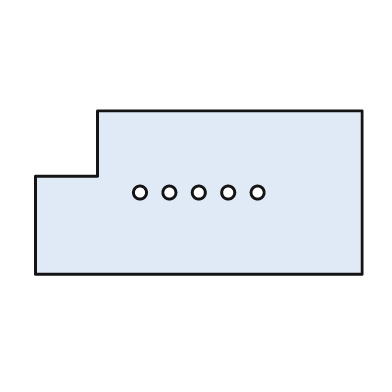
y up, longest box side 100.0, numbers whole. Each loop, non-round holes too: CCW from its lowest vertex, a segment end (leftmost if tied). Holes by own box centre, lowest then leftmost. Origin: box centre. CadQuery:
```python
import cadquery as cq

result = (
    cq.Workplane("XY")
    .moveTo(-50.0, -25.0)
    .lineTo(50.0, -25.0)
    .lineTo(50.0, 25.0)
    .lineTo(-31.0, 25.0)
    .lineTo(-31.0, 5.0)
    .lineTo(-50.0, 5.0)
    .close()
    .moveTo(-18.0, 0.0)
    .circle(2.0)
    .moveTo(-9.0, 0.0)
    .circle(2.0)
    .moveTo(0.0, 0.0)
    .circle(2.0)
    .moveTo(9.0, 0.0)
    .circle(2.0)
    .moveTo(18.0, 0.0)
    .circle(2.0)
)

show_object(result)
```